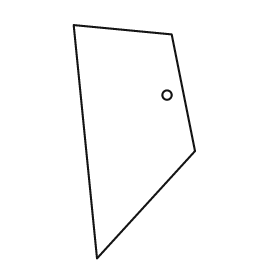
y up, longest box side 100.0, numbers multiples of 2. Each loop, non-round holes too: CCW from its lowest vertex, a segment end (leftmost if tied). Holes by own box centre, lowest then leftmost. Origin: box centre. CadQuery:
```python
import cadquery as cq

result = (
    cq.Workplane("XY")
    .moveTo(-16.0, -50.0)
    .lineTo(26.0, -4.0)
    .lineTo(16.0, 46.0)
    .lineTo(-26.0, 50.0)
    .close()
    .moveTo(14.0, 20.0)
    .circle(2.0)
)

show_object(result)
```